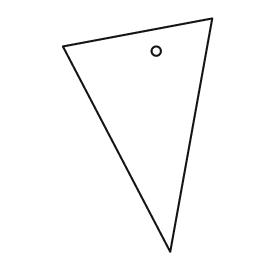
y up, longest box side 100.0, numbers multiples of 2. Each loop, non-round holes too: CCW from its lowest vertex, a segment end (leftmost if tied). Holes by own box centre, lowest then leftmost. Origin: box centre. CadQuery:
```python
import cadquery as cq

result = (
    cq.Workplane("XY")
    .moveTo(14.0, -50.0)
    .lineTo(32.0, 50.0)
    .lineTo(-32.0, 38.0)
    .close()
    .moveTo(8.0, 36.0)
    .circle(2.0)
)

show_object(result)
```